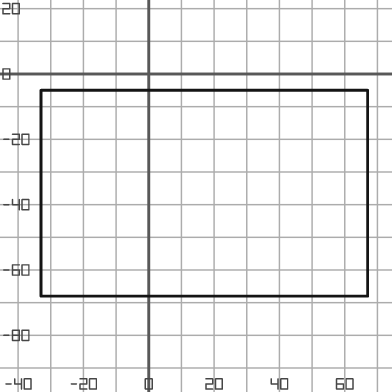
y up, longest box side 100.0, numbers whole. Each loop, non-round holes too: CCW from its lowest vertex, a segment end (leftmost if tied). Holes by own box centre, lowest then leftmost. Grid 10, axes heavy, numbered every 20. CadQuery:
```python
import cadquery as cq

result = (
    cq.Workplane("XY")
    .moveTo(-33.0, -68.0)
    .lineTo(67.0, -68.0)
    .lineTo(67.0, -5.0)
    .lineTo(-33.0, -5.0)
    .close()
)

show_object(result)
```